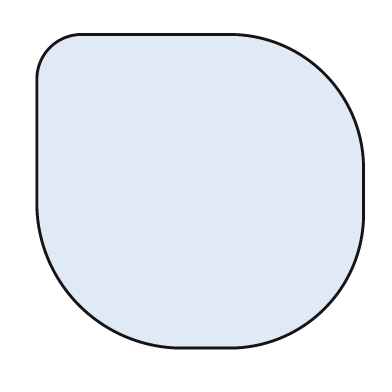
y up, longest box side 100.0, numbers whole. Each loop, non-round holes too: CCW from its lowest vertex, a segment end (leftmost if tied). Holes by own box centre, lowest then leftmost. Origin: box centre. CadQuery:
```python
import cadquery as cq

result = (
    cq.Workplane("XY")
    .moveTo(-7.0, -48.0)
    .lineTo(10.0, -48.0)
    .threePointArc((38.0, -36.0), (50.0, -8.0))
    .lineTo(50.0, 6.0)
    .threePointArc((38.0, 36.0), (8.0, 48.0))
    .lineTo(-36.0, 48.0)
    .threePointArc((-46.0, 44.0), (-50.0, 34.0))
    .lineTo(-50.0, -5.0)
    .threePointArc((-37.0, -35.0), (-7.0, -48.0))
    .close()
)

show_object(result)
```